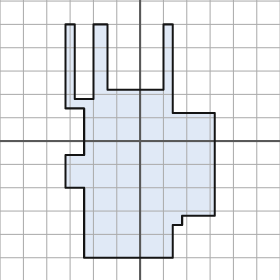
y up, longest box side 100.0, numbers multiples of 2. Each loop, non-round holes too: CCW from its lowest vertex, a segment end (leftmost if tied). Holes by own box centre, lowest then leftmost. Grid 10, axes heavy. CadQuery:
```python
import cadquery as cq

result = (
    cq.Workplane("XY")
    .moveTo(-24.0, -50.0)
    .lineTo(14.0, -50.0)
    .lineTo(14.0, -36.0)
    .lineTo(18.0, -36.0)
    .lineTo(18.0, -32.0)
    .lineTo(32.0, -32.0)
    .lineTo(32.0, 12.0)
    .lineTo(14.0, 12.0)
    .lineTo(14.0, 50.0)
    .lineTo(10.0, 50.0)
    .lineTo(10.0, 22.0)
    .lineTo(-14.0, 22.0)
    .lineTo(-14.0, 50.0)
    .lineTo(-20.0, 50.0)
    .lineTo(-20.0, 18.0)
    .lineTo(-28.0, 18.0)
    .lineTo(-28.0, 50.0)
    .lineTo(-32.0, 50.0)
    .lineTo(-32.0, 14.0)
    .lineTo(-24.0, 14.0)
    .lineTo(-24.0, -6.0)
    .lineTo(-32.0, -6.0)
    .lineTo(-32.0, -20.0)
    .lineTo(-24.0, -20.0)
    .close()
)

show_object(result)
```